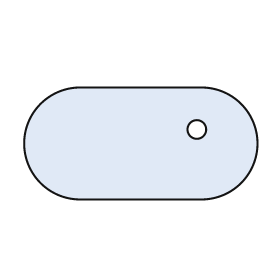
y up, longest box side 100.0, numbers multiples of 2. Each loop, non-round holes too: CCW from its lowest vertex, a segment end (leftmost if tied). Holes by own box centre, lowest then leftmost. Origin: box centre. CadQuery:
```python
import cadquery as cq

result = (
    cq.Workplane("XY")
    .moveTo(-26.0, -24.0)
    .lineTo(26.0, -24.0)
    .threePointArc((50.0, 0.0), (26.0, 24.0))
    .lineTo(-26.0, 24.0)
    .threePointArc((-50.0, 0.0), (-26.0, -24.0))
    .close()
    .moveTo(24.0, 6.0)
    .circle(4.0)
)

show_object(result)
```